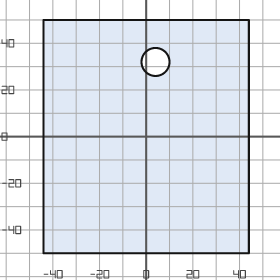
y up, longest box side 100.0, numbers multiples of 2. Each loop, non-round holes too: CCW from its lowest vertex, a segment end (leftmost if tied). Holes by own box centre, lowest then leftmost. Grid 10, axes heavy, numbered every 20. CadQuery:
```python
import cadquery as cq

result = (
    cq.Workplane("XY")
    .moveTo(-44.0, -50.0)
    .lineTo(44.0, -50.0)
    .lineTo(44.0, 50.0)
    .lineTo(-44.0, 50.0)
    .close()
    .moveTo(4.0, 32.0)
    .circle(6.0)
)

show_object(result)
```